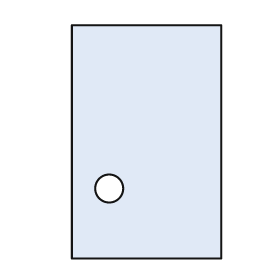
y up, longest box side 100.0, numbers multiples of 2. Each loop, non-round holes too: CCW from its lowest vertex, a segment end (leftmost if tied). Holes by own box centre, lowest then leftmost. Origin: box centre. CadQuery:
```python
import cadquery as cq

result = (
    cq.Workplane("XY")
    .moveTo(-32.0, -50.0)
    .lineTo(32.0, -50.0)
    .lineTo(32.0, 50.0)
    .lineTo(-32.0, 50.0)
    .close()
    .moveTo(-16.0, -20.0)
    .circle(6.0)
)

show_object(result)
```